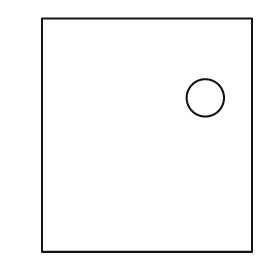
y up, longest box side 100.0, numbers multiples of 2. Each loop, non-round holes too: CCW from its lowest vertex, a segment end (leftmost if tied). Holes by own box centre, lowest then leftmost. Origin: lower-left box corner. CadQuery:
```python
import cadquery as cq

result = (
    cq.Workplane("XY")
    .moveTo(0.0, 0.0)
    .lineTo(90.0, 0.0)
    .lineTo(90.0, 100.0)
    .lineTo(0.0, 100.0)
    .close()
    .moveTo(70.0, 66.0)
    .circle(8.0)
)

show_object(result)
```